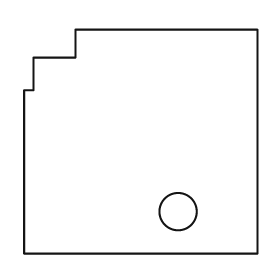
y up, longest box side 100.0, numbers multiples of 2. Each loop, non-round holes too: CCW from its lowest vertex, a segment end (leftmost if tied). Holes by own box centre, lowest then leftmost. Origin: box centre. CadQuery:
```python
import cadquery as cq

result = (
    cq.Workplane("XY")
    .moveTo(-50.0, -48.0)
    .lineTo(50.0, -48.0)
    .lineTo(50.0, 48.0)
    .lineTo(-28.0, 48.0)
    .lineTo(-28.0, 36.0)
    .lineTo(-46.0, 36.0)
    .lineTo(-46.0, 22.0)
    .lineTo(-50.0, 22.0)
    .close()
    .moveTo(16.0, -30.0)
    .circle(8.0)
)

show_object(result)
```